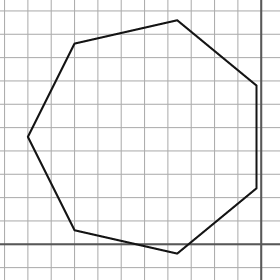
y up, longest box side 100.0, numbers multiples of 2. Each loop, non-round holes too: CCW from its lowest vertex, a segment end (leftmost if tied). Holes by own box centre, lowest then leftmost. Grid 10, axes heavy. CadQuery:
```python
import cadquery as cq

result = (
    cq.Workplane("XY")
    .moveTo(-36.0, -4.0)
    .lineTo(-2.0, 24.0)
    .lineTo(-2.0, 68.0)
    .lineTo(-36.0, 96.0)
    .lineTo(-80.0, 86.0)
    .lineTo(-100.0, 46.0)
    .lineTo(-80.0, 6.0)
    .close()
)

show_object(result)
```